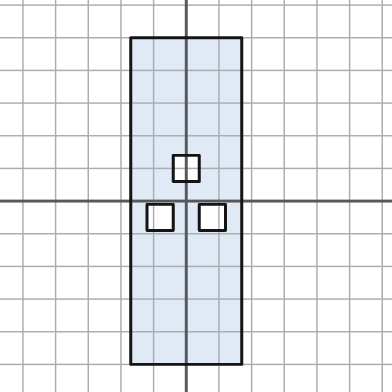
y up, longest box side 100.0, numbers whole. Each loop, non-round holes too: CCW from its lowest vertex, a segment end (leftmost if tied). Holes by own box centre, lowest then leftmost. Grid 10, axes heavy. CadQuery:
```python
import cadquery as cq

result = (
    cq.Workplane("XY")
    .moveTo(-17.0, -50.0)
    .lineTo(17.0, -50.0)
    .lineTo(17.0, 50.0)
    .lineTo(-17.0, 50.0)
    .close()
    .moveTo(-12.0, -9.0)
    .lineTo(-4.0, -9.0)
    .lineTo(-4.0, -1.0)
    .lineTo(-12.0, -1.0)
    .close()
    .moveTo(4.0, -9.0)
    .lineTo(12.0, -9.0)
    .lineTo(12.0, -1.0)
    .lineTo(4.0, -1.0)
    .close()
    .moveTo(-4.0, 6.0)
    .lineTo(4.0, 6.0)
    .lineTo(4.0, 14.0)
    .lineTo(-4.0, 14.0)
    .close()
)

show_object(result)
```